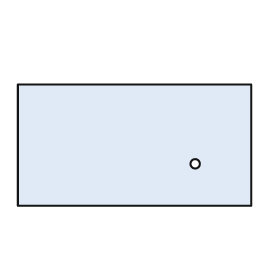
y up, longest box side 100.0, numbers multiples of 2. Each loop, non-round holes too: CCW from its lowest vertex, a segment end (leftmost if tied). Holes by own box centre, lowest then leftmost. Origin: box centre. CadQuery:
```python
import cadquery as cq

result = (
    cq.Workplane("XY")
    .moveTo(-50.0, -26.0)
    .lineTo(50.0, -26.0)
    .lineTo(50.0, 26.0)
    .lineTo(-50.0, 26.0)
    .close()
    .moveTo(26.0, -8.0)
    .circle(2.0)
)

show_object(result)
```